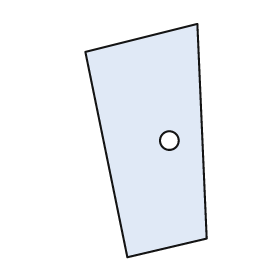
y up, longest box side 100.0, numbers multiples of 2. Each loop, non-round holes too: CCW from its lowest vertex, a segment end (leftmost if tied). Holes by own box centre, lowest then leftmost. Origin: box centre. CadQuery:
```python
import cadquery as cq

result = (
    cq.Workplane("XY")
    .moveTo(-8.0, -50.0)
    .lineTo(26.0, -42.0)
    .lineTo(22.0, 50.0)
    .lineTo(-26.0, 38.0)
    .close()
    .moveTo(10.0, 0.0)
    .circle(4.0)
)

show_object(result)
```